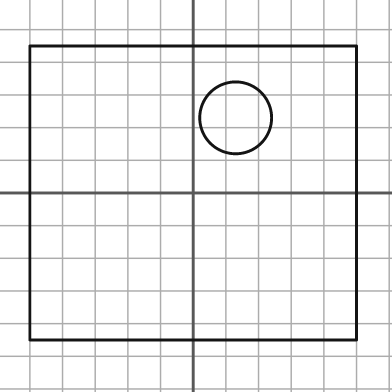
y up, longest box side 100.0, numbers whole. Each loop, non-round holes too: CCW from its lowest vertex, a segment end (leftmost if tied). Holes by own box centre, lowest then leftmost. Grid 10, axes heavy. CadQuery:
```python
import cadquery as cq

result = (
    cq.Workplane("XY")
    .moveTo(-50.0, -45.0)
    .lineTo(50.0, -45.0)
    .lineTo(50.0, 45.0)
    .lineTo(-50.0, 45.0)
    .close()
    .moveTo(13.0, 23.0)
    .circle(11.0)
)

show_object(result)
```